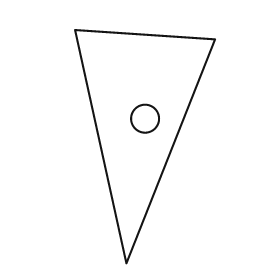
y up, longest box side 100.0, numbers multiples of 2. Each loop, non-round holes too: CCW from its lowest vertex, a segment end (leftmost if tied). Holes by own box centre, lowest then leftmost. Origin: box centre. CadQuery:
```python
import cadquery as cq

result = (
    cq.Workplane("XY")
    .moveTo(-8.0, -50.0)
    .lineTo(30.0, 46.0)
    .lineTo(-30.0, 50.0)
    .close()
    .moveTo(0.0, 12.0)
    .circle(6.0)
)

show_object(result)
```